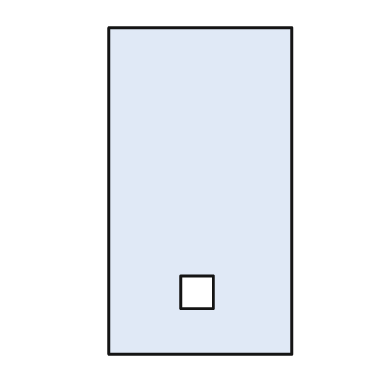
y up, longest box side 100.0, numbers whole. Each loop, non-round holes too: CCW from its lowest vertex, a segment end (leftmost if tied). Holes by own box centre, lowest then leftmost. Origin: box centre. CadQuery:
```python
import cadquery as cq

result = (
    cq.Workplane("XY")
    .moveTo(-28.0, -50.0)
    .lineTo(28.0, -50.0)
    .lineTo(28.0, 50.0)
    .lineTo(-28.0, 50.0)
    .close()
    .moveTo(-6.0, -36.0)
    .lineTo(4.0, -36.0)
    .lineTo(4.0, -26.0)
    .lineTo(-6.0, -26.0)
    .close()
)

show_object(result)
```